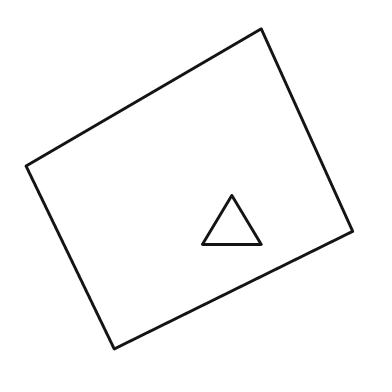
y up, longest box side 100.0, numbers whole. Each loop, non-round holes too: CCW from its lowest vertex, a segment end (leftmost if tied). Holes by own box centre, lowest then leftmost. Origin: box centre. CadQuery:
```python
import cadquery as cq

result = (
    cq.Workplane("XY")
    .moveTo(-23.0, -49.0)
    .lineTo(50.0, -13.0)
    .lineTo(22.0, 49.0)
    .lineTo(-50.0, 7.0)
    .close()
    .moveTo(4.0, -17.0)
    .lineTo(22.0, -17.0)
    .lineTo(13.0, -2.0)
    .close()
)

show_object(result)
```